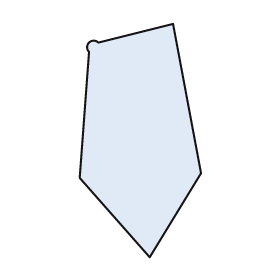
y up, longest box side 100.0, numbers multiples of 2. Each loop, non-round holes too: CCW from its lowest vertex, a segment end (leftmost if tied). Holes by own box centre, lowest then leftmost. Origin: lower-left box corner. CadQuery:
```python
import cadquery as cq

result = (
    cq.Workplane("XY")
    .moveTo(30.0, 0.0)
    .lineTo(52.0, 36.0)
    .lineTo(40.0, 100.0)
    .lineTo(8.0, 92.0)
    .threePointArc((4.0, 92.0), (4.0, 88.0))
    .lineTo(0.0, 34.0)
    .close()
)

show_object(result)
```